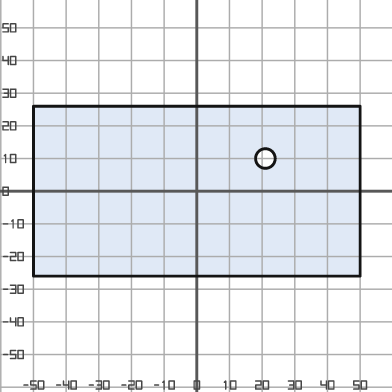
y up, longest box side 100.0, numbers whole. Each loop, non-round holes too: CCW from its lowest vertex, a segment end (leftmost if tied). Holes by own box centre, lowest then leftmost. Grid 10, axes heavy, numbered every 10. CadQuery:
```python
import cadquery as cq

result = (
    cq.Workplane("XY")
    .moveTo(-50.0, -26.0)
    .lineTo(50.0, -26.0)
    .lineTo(50.0, 26.0)
    .lineTo(-50.0, 26.0)
    .close()
    .moveTo(21.0, 10.0)
    .circle(3.0)
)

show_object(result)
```